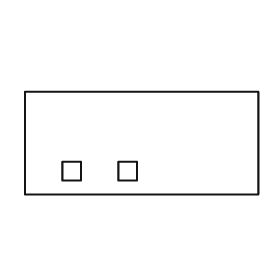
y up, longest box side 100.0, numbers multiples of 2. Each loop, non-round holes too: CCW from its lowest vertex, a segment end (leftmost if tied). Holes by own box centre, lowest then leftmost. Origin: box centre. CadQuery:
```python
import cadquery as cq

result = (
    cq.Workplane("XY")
    .moveTo(-50.0, -22.0)
    .lineTo(50.0, -22.0)
    .lineTo(50.0, 22.0)
    .lineTo(-50.0, 22.0)
    .close()
    .moveTo(-34.0, -16.0)
    .lineTo(-26.0, -16.0)
    .lineTo(-26.0, -8.0)
    .lineTo(-34.0, -8.0)
    .close()
    .moveTo(-10.0, -16.0)
    .lineTo(-2.0, -16.0)
    .lineTo(-2.0, -8.0)
    .lineTo(-10.0, -8.0)
    .close()
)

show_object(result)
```